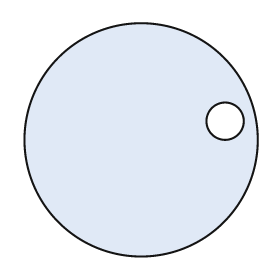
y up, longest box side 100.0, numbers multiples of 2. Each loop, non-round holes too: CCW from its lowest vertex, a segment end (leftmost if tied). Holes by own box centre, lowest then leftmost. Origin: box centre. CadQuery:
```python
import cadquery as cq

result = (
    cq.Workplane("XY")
    .moveTo(0.0, 0.0)
    .circle(50.0)
    .moveTo(36.0, 8.0)
    .circle(8.0)
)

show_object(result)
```